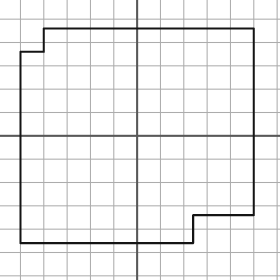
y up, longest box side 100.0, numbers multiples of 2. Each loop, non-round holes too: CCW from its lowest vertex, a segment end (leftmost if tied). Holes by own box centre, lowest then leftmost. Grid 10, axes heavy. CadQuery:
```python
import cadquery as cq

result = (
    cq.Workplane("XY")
    .moveTo(-50.0, -46.0)
    .lineTo(24.0, -46.0)
    .lineTo(24.0, -34.0)
    .lineTo(50.0, -34.0)
    .lineTo(50.0, 46.0)
    .lineTo(-40.0, 46.0)
    .lineTo(-40.0, 36.0)
    .lineTo(-50.0, 36.0)
    .close()
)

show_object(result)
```